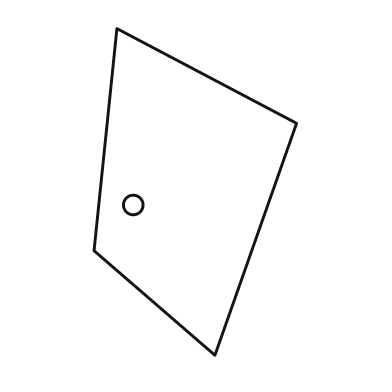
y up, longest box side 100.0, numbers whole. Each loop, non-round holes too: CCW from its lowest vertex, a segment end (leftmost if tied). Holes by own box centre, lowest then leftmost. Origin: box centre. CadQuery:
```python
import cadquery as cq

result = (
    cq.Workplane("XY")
    .moveTo(6.0, -50.0)
    .lineTo(31.0, 21.0)
    .lineTo(-24.0, 50.0)
    .lineTo(-31.0, -18.0)
    .close()
    .moveTo(-19.0, -4.0)
    .circle(3.0)
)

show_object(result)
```